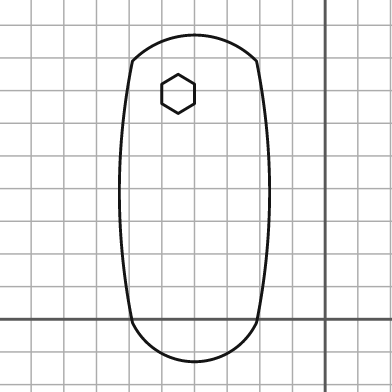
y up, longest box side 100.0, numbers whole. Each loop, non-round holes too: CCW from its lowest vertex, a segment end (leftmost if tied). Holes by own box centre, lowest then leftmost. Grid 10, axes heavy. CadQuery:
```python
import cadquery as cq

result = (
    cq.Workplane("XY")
    .moveTo(-59.0, -1.0)
    .threePointArc((-40.0, -13.0), (-21.0, -1.0))
    .threePointArc((-17.0, 39.0), (-21.0, 79.0))
    .threePointArc((-40.0, 87.0), (-59.0, 79.0))
    .threePointArc((-63.0, 39.0), (-59.0, -1.0))
    .close()
    .moveTo(-45.0, 63.0)
    .lineTo(-40.0, 66.0)
    .lineTo(-40.0, 72.0)
    .lineTo(-45.0, 75.0)
    .lineTo(-50.0, 72.0)
    .lineTo(-50.0, 66.0)
    .close()
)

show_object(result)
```